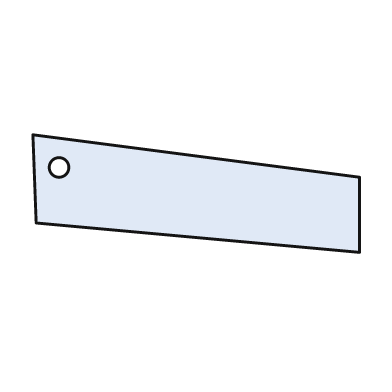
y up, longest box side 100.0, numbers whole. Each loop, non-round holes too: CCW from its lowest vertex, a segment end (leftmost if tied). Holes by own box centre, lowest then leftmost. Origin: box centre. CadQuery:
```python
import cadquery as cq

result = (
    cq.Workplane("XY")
    .moveTo(50.0, -18.0)
    .lineTo(50.0, 5.0)
    .lineTo(-50.0, 18.0)
    .lineTo(-49.0, -9.0)
    .close()
    .moveTo(-42.0, 8.0)
    .circle(3.0)
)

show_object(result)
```